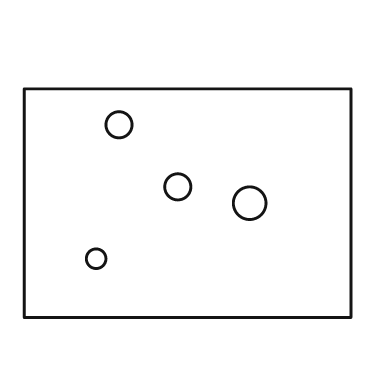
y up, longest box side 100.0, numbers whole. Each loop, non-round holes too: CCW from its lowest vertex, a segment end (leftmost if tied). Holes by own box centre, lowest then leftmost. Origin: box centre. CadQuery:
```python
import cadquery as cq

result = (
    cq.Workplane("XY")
    .moveTo(-50.0, -35.0)
    .lineTo(50.0, -35.0)
    .lineTo(50.0, 35.0)
    .lineTo(-50.0, 35.0)
    .close()
    .moveTo(-28.0, -17.0)
    .circle(3.0)
    .moveTo(19.0, 0.0)
    .circle(5.0)
    .moveTo(-3.0, 5.0)
    .circle(4.0)
    .moveTo(-21.0, 24.0)
    .circle(4.0)
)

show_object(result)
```